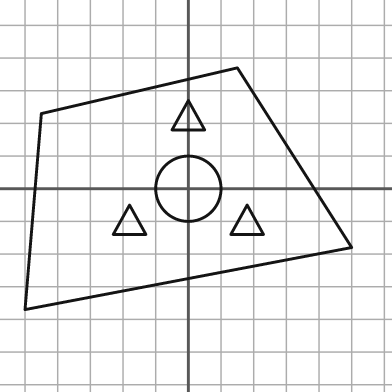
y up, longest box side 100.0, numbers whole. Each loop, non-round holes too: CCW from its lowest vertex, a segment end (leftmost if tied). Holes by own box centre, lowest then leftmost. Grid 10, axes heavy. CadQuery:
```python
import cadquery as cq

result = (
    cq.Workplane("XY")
    .moveTo(-50.0, -37.0)
    .lineTo(50.0, -18.0)
    .lineTo(15.0, 37.0)
    .lineTo(-45.0, 23.0)
    .close()
    .moveTo(-23.0, -14.0)
    .lineTo(-13.0, -14.0)
    .lineTo(-18.0, -5.0)
    .close()
    .moveTo(13.0, -14.0)
    .lineTo(23.0, -14.0)
    .lineTo(18.0, -5.0)
    .close()
    .moveTo(0.0, 0.0)
    .circle(10.0)
    .moveTo(-5.0, 18.0)
    .lineTo(5.0, 18.0)
    .lineTo(0.0, 27.0)
    .close()
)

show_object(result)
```